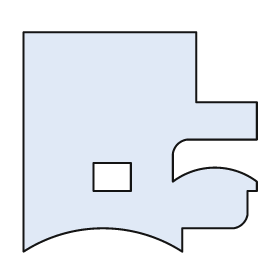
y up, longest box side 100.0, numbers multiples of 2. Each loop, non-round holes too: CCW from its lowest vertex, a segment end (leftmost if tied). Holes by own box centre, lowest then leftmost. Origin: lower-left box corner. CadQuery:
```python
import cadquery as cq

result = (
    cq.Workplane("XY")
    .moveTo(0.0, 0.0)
    .threePointArc((34.0, 10.0), (68.0, 0.0))
    .lineTo(68.0, 10.0)
    .lineTo(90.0, 10.0)
    .threePointArc((94.0, 12.0), (96.0, 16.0))
    .lineTo(96.0, 26.0)
    .lineTo(100.0, 26.0)
    .lineTo(100.0, 30.0)
    .threePointArc((82.0, 36.0), (64.0, 30.0))
    .lineTo(64.0, 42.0)
    .threePointArc((66.0, 46.0), (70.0, 48.0))
    .lineTo(100.0, 48.0)
    .lineTo(100.0, 64.0)
    .lineTo(74.0, 64.0)
    .lineTo(74.0, 94.0)
    .lineTo(0.0, 94.0)
    .close()
    .moveTo(30.0, 26.0)
    .lineTo(46.0, 26.0)
    .lineTo(46.0, 38.0)
    .lineTo(30.0, 38.0)
    .close()
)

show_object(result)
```